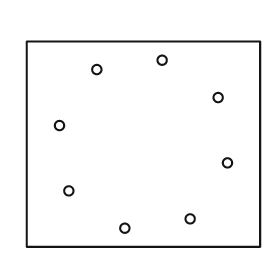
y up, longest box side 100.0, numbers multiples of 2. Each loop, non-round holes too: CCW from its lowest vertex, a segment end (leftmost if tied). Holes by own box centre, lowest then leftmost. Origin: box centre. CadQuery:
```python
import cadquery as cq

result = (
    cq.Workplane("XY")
    .moveTo(-50.0, -44.0)
    .lineTo(50.0, -44.0)
    .lineTo(50.0, 44.0)
    .lineTo(-50.0, 44.0)
    .close()
    .moveTo(-8.0, -36.0)
    .circle(2.0)
    .moveTo(20.0, -32.0)
    .circle(2.0)
    .moveTo(-32.0, -20.0)
    .circle(2.0)
    .moveTo(36.0, -8.0)
    .circle(2.0)
    .moveTo(-36.0, 8.0)
    .circle(2.0)
    .moveTo(32.0, 20.0)
    .circle(2.0)
    .moveTo(-20.0, 32.0)
    .circle(2.0)
    .moveTo(8.0, 36.0)
    .circle(2.0)
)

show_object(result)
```